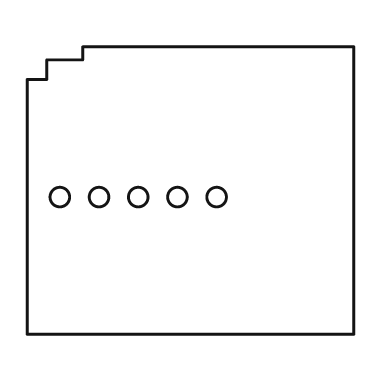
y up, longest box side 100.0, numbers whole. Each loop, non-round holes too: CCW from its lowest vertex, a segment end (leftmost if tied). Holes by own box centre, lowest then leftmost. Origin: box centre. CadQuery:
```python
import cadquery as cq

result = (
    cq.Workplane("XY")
    .moveTo(-50.0, -44.0)
    .lineTo(50.0, -44.0)
    .lineTo(50.0, 44.0)
    .lineTo(-33.0, 44.0)
    .lineTo(-33.0, 40.0)
    .lineTo(-44.0, 40.0)
    .lineTo(-44.0, 34.0)
    .lineTo(-50.0, 34.0)
    .close()
    .moveTo(-40.0, -2.0)
    .circle(3.0)
    .moveTo(-28.0, -2.0)
    .circle(3.0)
    .moveTo(-16.0, -2.0)
    .circle(3.0)
    .moveTo(-4.0, -2.0)
    .circle(3.0)
    .moveTo(8.0, -2.0)
    .circle(3.0)
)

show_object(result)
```